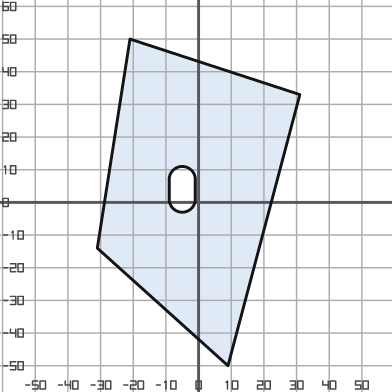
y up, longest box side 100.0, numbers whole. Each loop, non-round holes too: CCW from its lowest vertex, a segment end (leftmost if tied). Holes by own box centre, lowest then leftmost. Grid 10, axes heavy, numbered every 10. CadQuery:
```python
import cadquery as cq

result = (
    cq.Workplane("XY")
    .moveTo(9.0, -50.0)
    .lineTo(31.0, 33.0)
    .lineTo(-21.0, 50.0)
    .lineTo(-31.0, -14.0)
    .close()
    .moveTo(-9.0, 1.0)
    .threePointArc((-5.0, -3.0), (-1.0, 1.0))
    .lineTo(-1.0, 7.0)
    .threePointArc((-5.0, 11.0), (-9.0, 7.0))
    .close()
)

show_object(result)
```